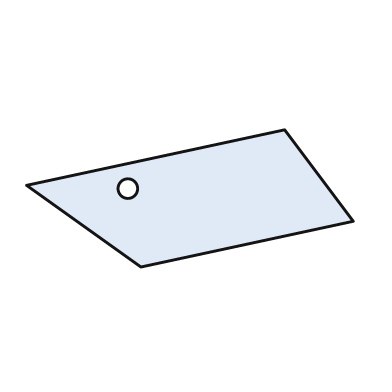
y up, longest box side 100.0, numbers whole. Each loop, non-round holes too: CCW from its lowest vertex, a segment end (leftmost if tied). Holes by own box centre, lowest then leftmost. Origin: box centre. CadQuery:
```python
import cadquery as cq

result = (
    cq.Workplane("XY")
    .moveTo(-15.0, -21.0)
    .lineTo(50.0, -7.0)
    .lineTo(29.0, 21.0)
    .lineTo(-50.0, 4.0)
    .close()
    .moveTo(-19.0, 3.0)
    .circle(3.0)
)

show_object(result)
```